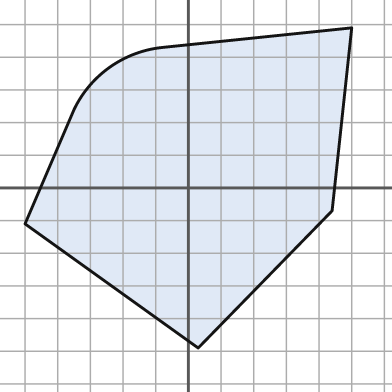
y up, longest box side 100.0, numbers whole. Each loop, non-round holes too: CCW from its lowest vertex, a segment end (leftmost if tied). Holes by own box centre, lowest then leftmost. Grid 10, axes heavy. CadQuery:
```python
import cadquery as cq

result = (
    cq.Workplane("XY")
    .moveTo(3.0, -49.0)
    .lineTo(44.0, -7.0)
    .lineTo(50.0, 49.0)
    .lineTo(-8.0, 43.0)
    .threePointArc((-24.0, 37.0), (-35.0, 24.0))
    .lineTo(-50.0, -11.0)
    .close()
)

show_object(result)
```